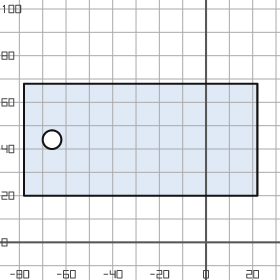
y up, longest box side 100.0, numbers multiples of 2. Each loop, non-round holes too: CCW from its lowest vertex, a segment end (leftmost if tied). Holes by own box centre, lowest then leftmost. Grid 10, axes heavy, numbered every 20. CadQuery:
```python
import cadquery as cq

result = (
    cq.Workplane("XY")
    .moveTo(-78.0, 20.0)
    .lineTo(22.0, 20.0)
    .lineTo(22.0, 68.0)
    .lineTo(-78.0, 68.0)
    .close()
    .moveTo(-66.0, 44.0)
    .circle(4.0)
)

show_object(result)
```